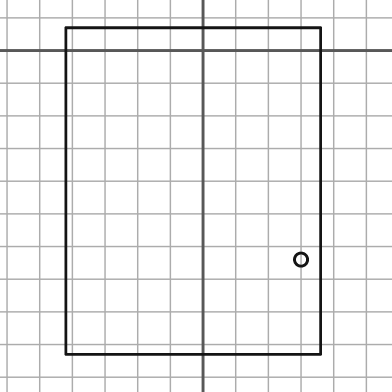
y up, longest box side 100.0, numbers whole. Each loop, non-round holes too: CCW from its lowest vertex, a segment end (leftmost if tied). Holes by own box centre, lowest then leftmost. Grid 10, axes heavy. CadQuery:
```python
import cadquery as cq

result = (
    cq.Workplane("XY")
    .moveTo(-42.0, -93.0)
    .lineTo(36.0, -93.0)
    .lineTo(36.0, 7.0)
    .lineTo(-42.0, 7.0)
    .close()
    .moveTo(30.0, -64.0)
    .circle(2.0)
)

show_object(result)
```